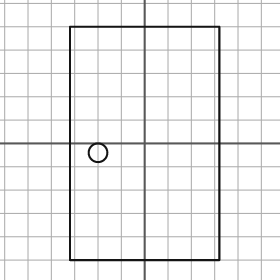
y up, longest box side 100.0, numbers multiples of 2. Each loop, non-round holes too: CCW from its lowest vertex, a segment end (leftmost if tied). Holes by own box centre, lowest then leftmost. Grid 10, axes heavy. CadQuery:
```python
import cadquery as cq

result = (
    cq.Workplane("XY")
    .moveTo(-32.0, -50.0)
    .lineTo(32.0, -50.0)
    .lineTo(32.0, 50.0)
    .lineTo(-32.0, 50.0)
    .close()
    .moveTo(-20.0, -4.0)
    .circle(4.0)
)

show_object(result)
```